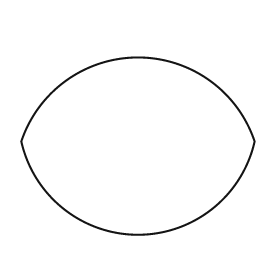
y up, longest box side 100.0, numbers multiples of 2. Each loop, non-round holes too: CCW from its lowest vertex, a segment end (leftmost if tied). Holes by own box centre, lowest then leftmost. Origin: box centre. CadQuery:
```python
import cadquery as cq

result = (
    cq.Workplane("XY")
    .moveTo(-50.0, 2.0)
    .threePointArc((0.0, -38.0), (50.0, 2.0))
    .threePointArc((0.0, 38.0), (-50.0, 2.0))
    .close()
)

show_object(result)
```